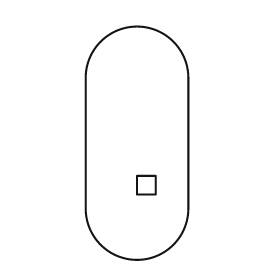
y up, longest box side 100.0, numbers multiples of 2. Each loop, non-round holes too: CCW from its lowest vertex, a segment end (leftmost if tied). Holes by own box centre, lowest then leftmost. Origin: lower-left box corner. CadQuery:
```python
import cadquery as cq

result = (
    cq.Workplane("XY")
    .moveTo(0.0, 22.0)
    .threePointArc((22.0, 0.0), (44.0, 22.0))
    .lineTo(44.0, 78.0)
    .threePointArc((22.0, 100.0), (0.0, 78.0))
    .close()
    .moveTo(22.0, 28.0)
    .lineTo(30.0, 28.0)
    .lineTo(30.0, 36.0)
    .lineTo(22.0, 36.0)
    .close()
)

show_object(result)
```